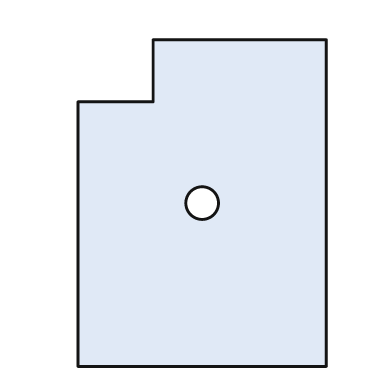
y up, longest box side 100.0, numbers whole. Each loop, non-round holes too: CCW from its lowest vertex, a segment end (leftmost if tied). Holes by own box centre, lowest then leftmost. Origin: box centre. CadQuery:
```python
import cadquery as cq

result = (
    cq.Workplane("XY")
    .moveTo(-38.0, -50.0)
    .lineTo(38.0, -50.0)
    .lineTo(38.0, 50.0)
    .lineTo(-15.0, 50.0)
    .lineTo(-15.0, 31.0)
    .lineTo(-38.0, 31.0)
    .close()
    .moveTo(0.0, 0.0)
    .circle(5.0)
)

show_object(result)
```